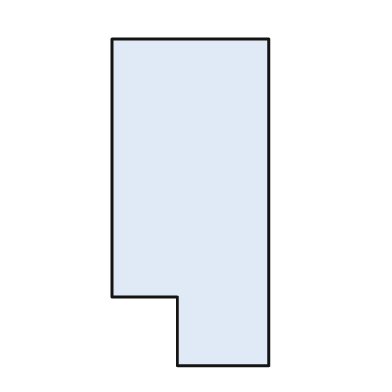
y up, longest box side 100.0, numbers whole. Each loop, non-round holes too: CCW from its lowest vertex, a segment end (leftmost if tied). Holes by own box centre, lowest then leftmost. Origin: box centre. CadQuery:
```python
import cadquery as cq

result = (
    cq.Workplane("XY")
    .moveTo(-4.0, -50.0)
    .lineTo(24.0, -50.0)
    .lineTo(24.0, 50.0)
    .lineTo(-24.0, 50.0)
    .lineTo(-24.0, -29.0)
    .lineTo(-4.0, -29.0)
    .close()
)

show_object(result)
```